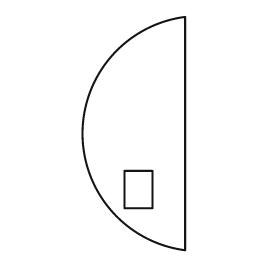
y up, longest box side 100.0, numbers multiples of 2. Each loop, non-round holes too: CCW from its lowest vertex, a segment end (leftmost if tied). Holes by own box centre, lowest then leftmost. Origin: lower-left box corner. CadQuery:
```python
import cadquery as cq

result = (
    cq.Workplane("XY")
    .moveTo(44.0, 0.0)
    .lineTo(44.0, 100.0)
    .threePointArc((0.0, 50.0), (44.0, 0.0))
    .close()
    .moveTo(18.0, 18.0)
    .lineTo(30.0, 18.0)
    .lineTo(30.0, 34.0)
    .lineTo(18.0, 34.0)
    .close()
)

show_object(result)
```